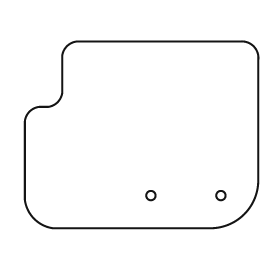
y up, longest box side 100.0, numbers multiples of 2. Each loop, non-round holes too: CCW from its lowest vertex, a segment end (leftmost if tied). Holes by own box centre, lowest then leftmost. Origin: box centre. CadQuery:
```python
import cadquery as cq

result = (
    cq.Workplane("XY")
    .moveTo(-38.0, -40.0)
    .lineTo(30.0, -40.0)
    .threePointArc((44.0, -34.0), (50.0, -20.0))
    .lineTo(50.0, 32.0)
    .threePointArc((48.0, 38.0), (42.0, 40.0))
    .lineTo(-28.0, 40.0)
    .threePointArc((-32.0, 38.0), (-34.0, 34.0))
    .lineTo(-34.0, 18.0)
    .threePointArc((-36.0, 14.0), (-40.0, 12.0))
    .lineTo(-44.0, 12.0)
    .threePointArc((-48.0, 10.0), (-50.0, 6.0))
    .lineTo(-50.0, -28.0)
    .threePointArc((-46.0, -36.0), (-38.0, -40.0))
    .close()
    .moveTo(4.0, -26.0)
    .circle(2.0)
    .moveTo(34.0, -26.0)
    .circle(2.0)
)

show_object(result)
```